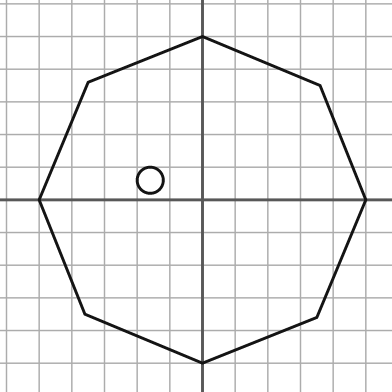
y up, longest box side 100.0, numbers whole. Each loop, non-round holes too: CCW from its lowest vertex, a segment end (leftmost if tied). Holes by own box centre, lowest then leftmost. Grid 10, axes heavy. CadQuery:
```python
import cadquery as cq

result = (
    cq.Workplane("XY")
    .moveTo(0.0, -50.0)
    .lineTo(35.0, -36.0)
    .lineTo(50.0, 0.0)
    .lineTo(36.0, 35.0)
    .lineTo(0.0, 50.0)
    .lineTo(-35.0, 36.0)
    .lineTo(-50.0, 0.0)
    .lineTo(-36.0, -35.0)
    .close()
    .moveTo(-16.0, 6.0)
    .circle(4.0)
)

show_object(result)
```